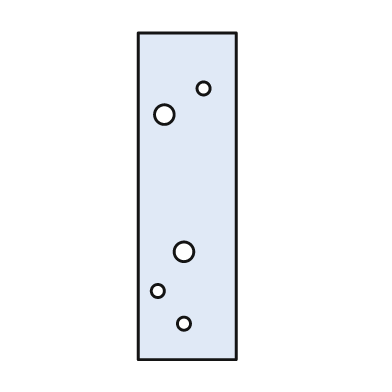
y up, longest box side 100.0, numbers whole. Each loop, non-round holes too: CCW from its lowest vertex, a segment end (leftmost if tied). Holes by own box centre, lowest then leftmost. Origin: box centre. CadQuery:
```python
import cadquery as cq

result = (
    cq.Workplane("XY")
    .moveTo(-15.0, -50.0)
    .lineTo(15.0, -50.0)
    .lineTo(15.0, 50.0)
    .lineTo(-15.0, 50.0)
    .close()
    .moveTo(-1.0, -39.0)
    .circle(2.0)
    .moveTo(-9.0, -29.0)
    .circle(2.0)
    .moveTo(-1.0, -17.0)
    .circle(3.0)
    .moveTo(-7.0, 25.0)
    .circle(3.0)
    .moveTo(5.0, 33.0)
    .circle(2.0)
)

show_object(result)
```